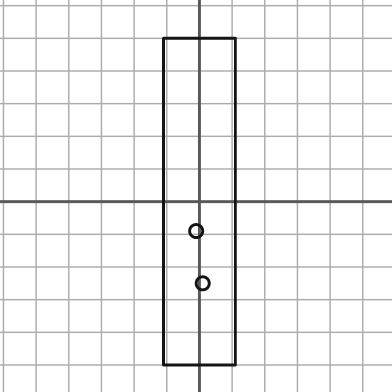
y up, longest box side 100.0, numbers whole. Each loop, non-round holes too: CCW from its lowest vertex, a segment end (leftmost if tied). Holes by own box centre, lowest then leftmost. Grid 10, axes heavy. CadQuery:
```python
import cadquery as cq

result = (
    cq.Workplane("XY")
    .moveTo(-11.0, -50.0)
    .lineTo(11.0, -50.0)
    .lineTo(11.0, 50.0)
    .lineTo(-11.0, 50.0)
    .close()
    .moveTo(1.0, -25.0)
    .circle(2.0)
    .moveTo(-1.0, -9.0)
    .circle(2.0)
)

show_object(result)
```